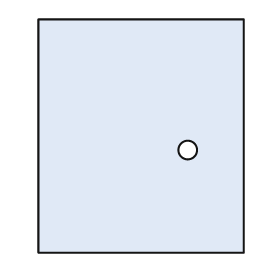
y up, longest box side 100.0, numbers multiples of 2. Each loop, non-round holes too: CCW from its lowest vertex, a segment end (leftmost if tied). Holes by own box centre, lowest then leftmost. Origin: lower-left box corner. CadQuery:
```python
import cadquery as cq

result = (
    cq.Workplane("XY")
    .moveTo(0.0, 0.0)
    .lineTo(88.0, 0.0)
    .lineTo(88.0, 100.0)
    .lineTo(0.0, 100.0)
    .close()
    .moveTo(64.0, 44.0)
    .circle(4.0)
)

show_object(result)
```